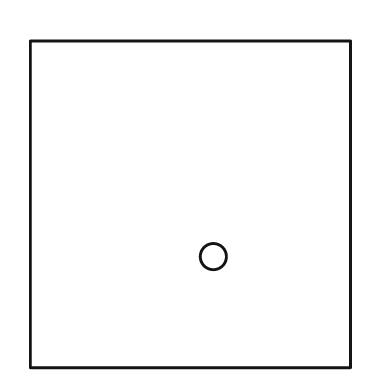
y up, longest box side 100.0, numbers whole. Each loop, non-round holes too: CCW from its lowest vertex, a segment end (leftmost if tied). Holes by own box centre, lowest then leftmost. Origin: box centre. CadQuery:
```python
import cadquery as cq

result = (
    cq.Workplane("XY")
    .moveTo(-49.0, -50.0)
    .lineTo(49.0, -50.0)
    .lineTo(49.0, 50.0)
    .lineTo(-49.0, 50.0)
    .close()
    .moveTo(7.0, -16.0)
    .circle(4.0)
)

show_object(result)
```